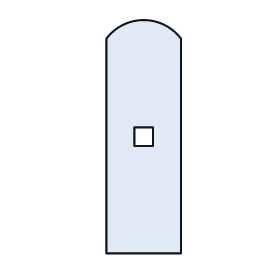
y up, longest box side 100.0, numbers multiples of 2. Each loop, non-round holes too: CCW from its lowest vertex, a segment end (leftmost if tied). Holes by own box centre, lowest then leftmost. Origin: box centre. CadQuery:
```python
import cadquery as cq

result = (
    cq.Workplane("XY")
    .moveTo(-16.0, -50.0)
    .lineTo(16.0, -50.0)
    .lineTo(16.0, 42.0)
    .threePointArc((0.0, 50.0), (-16.0, 42.0))
    .close()
    .moveTo(-4.0, -4.0)
    .lineTo(4.0, -4.0)
    .lineTo(4.0, 4.0)
    .lineTo(-4.0, 4.0)
    .close()
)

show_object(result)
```